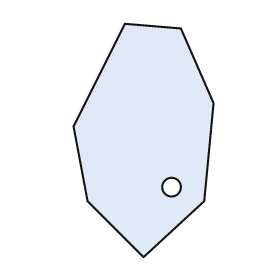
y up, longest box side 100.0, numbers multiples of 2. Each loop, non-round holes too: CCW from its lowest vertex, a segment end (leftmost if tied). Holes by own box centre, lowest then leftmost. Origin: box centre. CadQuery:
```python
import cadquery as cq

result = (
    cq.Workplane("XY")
    .moveTo(0.0, -50.0)
    .lineTo(26.0, -26.0)
    .lineTo(30.0, 16.0)
    .lineTo(16.0, 48.0)
    .lineTo(-8.0, 50.0)
    .lineTo(-30.0, 6.0)
    .lineTo(-24.0, -26.0)
    .close()
    .moveTo(12.0, -20.0)
    .circle(4.0)
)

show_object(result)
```